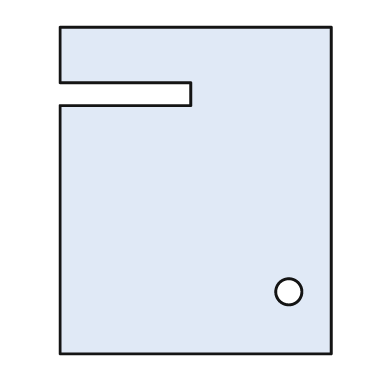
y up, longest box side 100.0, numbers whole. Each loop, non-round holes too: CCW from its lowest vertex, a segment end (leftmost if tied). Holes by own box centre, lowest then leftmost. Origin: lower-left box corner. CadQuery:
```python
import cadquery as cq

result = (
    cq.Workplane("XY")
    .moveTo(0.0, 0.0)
    .lineTo(83.0, 0.0)
    .lineTo(83.0, 100.0)
    .lineTo(0.0, 100.0)
    .lineTo(0.0, 83.0)
    .lineTo(40.0, 83.0)
    .lineTo(40.0, 76.0)
    .lineTo(0.0, 76.0)
    .close()
    .moveTo(70.0, 19.0)
    .circle(4.0)
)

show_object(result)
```